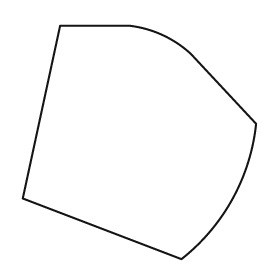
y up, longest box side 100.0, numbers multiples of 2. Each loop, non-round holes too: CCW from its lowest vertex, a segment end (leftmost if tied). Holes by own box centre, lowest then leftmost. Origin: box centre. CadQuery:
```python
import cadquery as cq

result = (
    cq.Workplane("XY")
    .moveTo(18.0, -50.0)
    .threePointArc((40.0, -24.0), (50.0, 8.0))
    .lineTo(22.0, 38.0)
    .threePointArc((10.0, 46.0), (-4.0, 50.0))
    .lineTo(-34.0, 50.0)
    .lineTo(-50.0, -24.0)
    .close()
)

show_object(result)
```